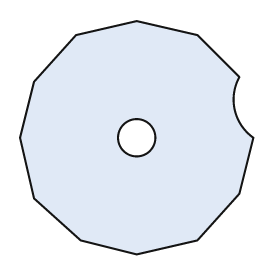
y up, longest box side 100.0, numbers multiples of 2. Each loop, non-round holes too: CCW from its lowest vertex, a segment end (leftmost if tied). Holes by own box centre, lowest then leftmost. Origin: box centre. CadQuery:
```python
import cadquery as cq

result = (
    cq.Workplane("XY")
    .moveTo(0.0, -50.0)
    .lineTo(26.0, -44.0)
    .lineTo(44.0, -24.0)
    .lineTo(50.0, 0.0)
    .threePointArc((42.0, 12.0), (44.0, 26.0))
    .lineTo(26.0, 44.0)
    .lineTo(0.0, 50.0)
    .lineTo(-26.0, 44.0)
    .lineTo(-44.0, 24.0)
    .lineTo(-50.0, 0.0)
    .lineTo(-44.0, -26.0)
    .lineTo(-24.0, -44.0)
    .close()
    .moveTo(0.0, 0.0)
    .circle(8.0)
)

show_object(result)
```